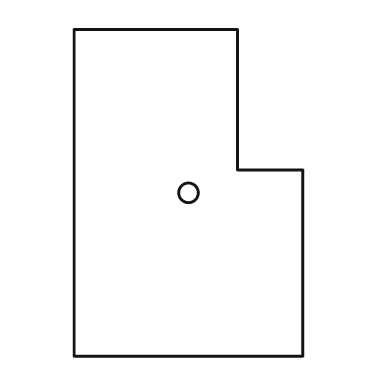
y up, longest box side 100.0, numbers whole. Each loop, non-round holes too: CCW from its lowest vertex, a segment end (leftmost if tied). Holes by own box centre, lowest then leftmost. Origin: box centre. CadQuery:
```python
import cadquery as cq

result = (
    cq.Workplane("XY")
    .moveTo(-35.0, -50.0)
    .lineTo(35.0, -50.0)
    .lineTo(35.0, 7.0)
    .lineTo(15.0, 7.0)
    .lineTo(15.0, 50.0)
    .lineTo(-35.0, 50.0)
    .close()
    .moveTo(0.0, 0.0)
    .circle(3.0)
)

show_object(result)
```